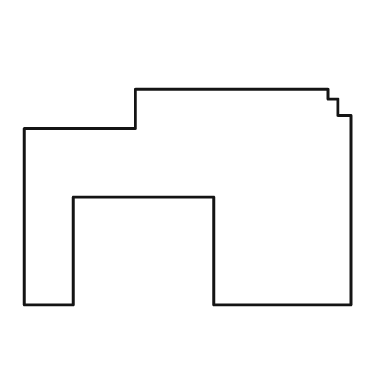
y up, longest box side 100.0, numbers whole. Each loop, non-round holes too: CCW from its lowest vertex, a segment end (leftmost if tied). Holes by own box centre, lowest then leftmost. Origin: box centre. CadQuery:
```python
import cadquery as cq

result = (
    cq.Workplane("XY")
    .moveTo(-50.0, -33.0)
    .lineTo(-35.0, -33.0)
    .lineTo(-35.0, 0.0)
    .lineTo(8.0, 0.0)
    .lineTo(8.0, -33.0)
    .lineTo(50.0, -33.0)
    .lineTo(50.0, 25.0)
    .lineTo(46.0, 25.0)
    .lineTo(46.0, 30.0)
    .lineTo(43.0, 30.0)
    .lineTo(43.0, 33.0)
    .lineTo(-16.0, 33.0)
    .lineTo(-16.0, 21.0)
    .lineTo(-50.0, 21.0)
    .close()
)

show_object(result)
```